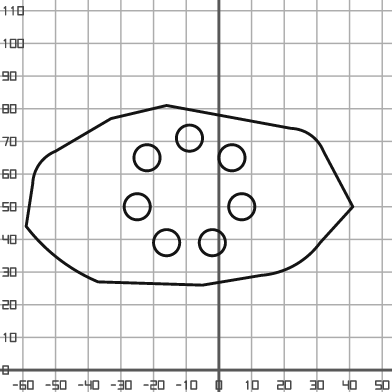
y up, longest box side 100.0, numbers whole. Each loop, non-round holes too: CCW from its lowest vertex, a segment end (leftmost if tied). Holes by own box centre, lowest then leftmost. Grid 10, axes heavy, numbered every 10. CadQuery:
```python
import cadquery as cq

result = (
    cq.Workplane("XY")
    .moveTo(-5.0, 26.0)
    .lineTo(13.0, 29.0)
    .threePointArc((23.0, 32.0), (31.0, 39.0))
    .lineTo(41.0, 50.0)
    .lineTo(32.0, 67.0)
    .threePointArc((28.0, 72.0), (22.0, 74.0))
    .lineTo(-16.0, 81.0)
    .lineTo(-33.0, 77.0)
    .lineTo(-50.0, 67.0)
    .threePointArc((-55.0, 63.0), (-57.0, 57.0))
    .lineTo(-59.0, 44.0)
    .threePointArc((-49.0, 34.0), (-37.0, 27.0))
    .close()
    .moveTo(-16.0, 39.0)
    .circle(4.0)
    .moveTo(-2.0, 39.0)
    .circle(4.0)
    .moveTo(-25.0, 50.0)
    .circle(4.0)
    .moveTo(7.0, 50.0)
    .circle(4.0)
    .moveTo(-22.0, 65.0)
    .circle(4.0)
    .moveTo(4.0, 65.0)
    .circle(4.0)
    .moveTo(-9.0, 71.0)
    .circle(4.0)
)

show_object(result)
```